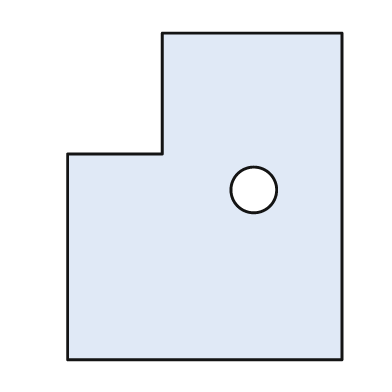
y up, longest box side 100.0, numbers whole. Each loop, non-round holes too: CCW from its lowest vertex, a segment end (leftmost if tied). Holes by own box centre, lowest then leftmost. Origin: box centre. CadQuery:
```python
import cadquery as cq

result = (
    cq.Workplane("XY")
    .moveTo(-42.0, -50.0)
    .lineTo(42.0, -50.0)
    .lineTo(42.0, 50.0)
    .lineTo(-13.0, 50.0)
    .lineTo(-13.0, 13.0)
    .lineTo(-42.0, 13.0)
    .close()
    .moveTo(15.0, 2.0)
    .circle(7.0)
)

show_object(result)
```